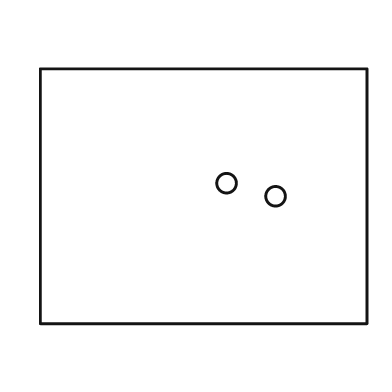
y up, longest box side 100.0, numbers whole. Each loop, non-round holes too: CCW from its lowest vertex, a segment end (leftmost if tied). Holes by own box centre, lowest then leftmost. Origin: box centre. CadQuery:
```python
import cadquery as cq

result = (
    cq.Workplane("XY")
    .moveTo(-50.0, -39.0)
    .lineTo(50.0, -39.0)
    .lineTo(50.0, 39.0)
    .lineTo(-50.0, 39.0)
    .close()
    .moveTo(22.0, 0.0)
    .circle(3.0)
    .moveTo(7.0, 4.0)
    .circle(3.0)
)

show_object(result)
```